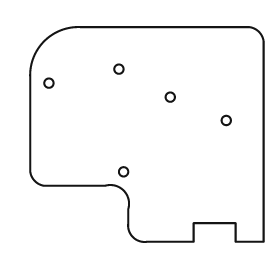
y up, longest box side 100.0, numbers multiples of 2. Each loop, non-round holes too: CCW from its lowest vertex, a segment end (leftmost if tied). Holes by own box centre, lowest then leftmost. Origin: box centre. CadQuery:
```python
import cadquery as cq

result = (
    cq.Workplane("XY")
    .moveTo(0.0, -46.0)
    .lineTo(20.0, -46.0)
    .lineTo(20.0, -38.0)
    .lineTo(38.0, -38.0)
    .lineTo(38.0, -46.0)
    .lineTo(50.0, -46.0)
    .lineTo(50.0, 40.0)
    .threePointArc((48.0, 44.0), (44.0, 46.0))
    .lineTo(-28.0, 46.0)
    .threePointArc((-44.0, 40.0), (-50.0, 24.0))
    .lineTo(-50.0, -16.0)
    .threePointArc((-48.0, -20.0), (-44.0, -22.0))
    .lineTo(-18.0, -22.0)
    .threePointArc((-10.0, -24.0), (-8.0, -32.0))
    .lineTo(-8.0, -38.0)
    .threePointArc((-6.0, -44.0), (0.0, -46.0))
    .close()
    .moveTo(-10.0, -16.0)
    .circle(2.0)
    .moveTo(34.0, 6.0)
    .circle(2.0)
    .moveTo(10.0, 16.0)
    .circle(2.0)
    .moveTo(-42.0, 22.0)
    .circle(2.0)
    .moveTo(-12.0, 28.0)
    .circle(2.0)
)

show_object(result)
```